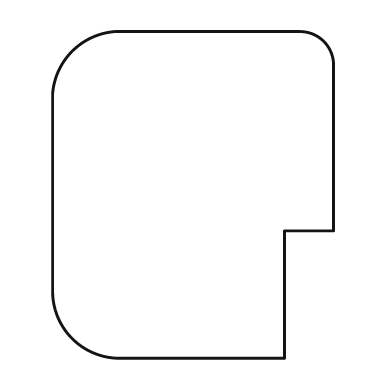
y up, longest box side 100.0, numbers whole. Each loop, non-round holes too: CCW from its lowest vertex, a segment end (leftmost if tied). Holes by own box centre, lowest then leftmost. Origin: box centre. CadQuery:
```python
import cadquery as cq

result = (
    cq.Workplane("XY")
    .moveTo(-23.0, -50.0)
    .lineTo(28.0, -50.0)
    .lineTo(28.0, -11.0)
    .lineTo(43.0, -11.0)
    .lineTo(43.0, 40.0)
    .threePointArc((40.0, 47.0), (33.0, 50.0))
    .lineTo(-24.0, 50.0)
    .threePointArc((-37.0, 44.0), (-43.0, 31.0))
    .lineTo(-43.0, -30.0)
    .threePointArc((-37.0, -44.0), (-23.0, -50.0))
    .close()
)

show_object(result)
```